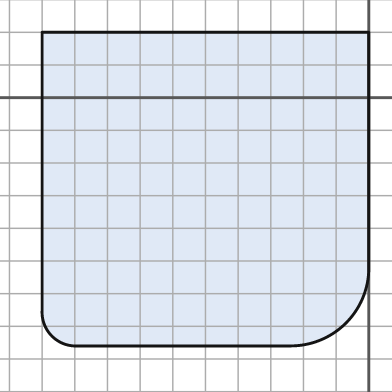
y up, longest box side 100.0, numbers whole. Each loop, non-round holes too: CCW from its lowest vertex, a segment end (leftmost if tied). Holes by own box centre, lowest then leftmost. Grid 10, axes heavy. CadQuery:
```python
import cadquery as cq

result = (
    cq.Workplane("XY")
    .moveTo(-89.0, -76.0)
    .lineTo(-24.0, -76.0)
    .threePointArc((-7.0, -69.0), (0.0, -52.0))
    .lineTo(0.0, 20.0)
    .lineTo(-100.0, 20.0)
    .lineTo(-100.0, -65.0)
    .threePointArc((-97.0, -73.0), (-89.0, -76.0))
    .close()
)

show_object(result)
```